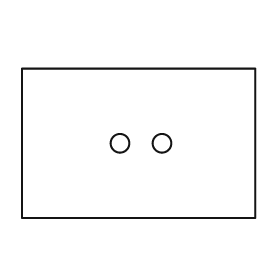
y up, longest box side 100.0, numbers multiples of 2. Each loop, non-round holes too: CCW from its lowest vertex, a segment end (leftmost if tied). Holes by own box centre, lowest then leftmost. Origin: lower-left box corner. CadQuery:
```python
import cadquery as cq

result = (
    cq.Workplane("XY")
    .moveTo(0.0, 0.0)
    .lineTo(100.0, 0.0)
    .lineTo(100.0, 64.0)
    .lineTo(0.0, 64.0)
    .close()
    .moveTo(42.0, 32.0)
    .circle(4.0)
    .moveTo(60.0, 32.0)
    .circle(4.0)
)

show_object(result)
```